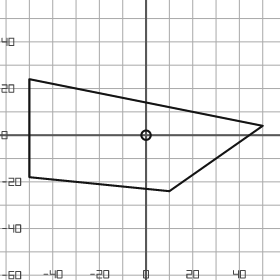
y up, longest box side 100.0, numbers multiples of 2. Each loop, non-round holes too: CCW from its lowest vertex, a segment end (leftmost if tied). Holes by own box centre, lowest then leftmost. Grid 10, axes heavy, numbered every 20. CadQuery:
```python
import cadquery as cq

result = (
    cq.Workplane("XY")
    .moveTo(10.0, -24.0)
    .lineTo(50.0, 4.0)
    .lineTo(-50.0, 24.0)
    .lineTo(-50.0, -18.0)
    .close()
    .moveTo(0.0, 0.0)
    .circle(2.0)
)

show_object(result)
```